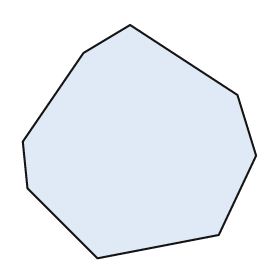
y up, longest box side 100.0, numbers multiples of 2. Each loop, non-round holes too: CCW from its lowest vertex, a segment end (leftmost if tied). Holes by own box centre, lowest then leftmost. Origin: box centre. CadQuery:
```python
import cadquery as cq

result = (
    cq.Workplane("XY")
    .moveTo(-18.0, -50.0)
    .lineTo(34.0, -40.0)
    .lineTo(50.0, -6.0)
    .lineTo(42.0, 20.0)
    .lineTo(-4.0, 50.0)
    .lineTo(-24.0, 38.0)
    .lineTo(-50.0, 0.0)
    .lineTo(-48.0, -20.0)
    .close()
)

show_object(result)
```